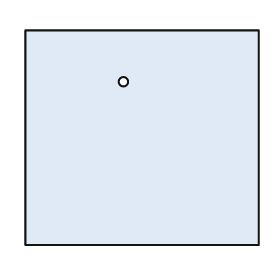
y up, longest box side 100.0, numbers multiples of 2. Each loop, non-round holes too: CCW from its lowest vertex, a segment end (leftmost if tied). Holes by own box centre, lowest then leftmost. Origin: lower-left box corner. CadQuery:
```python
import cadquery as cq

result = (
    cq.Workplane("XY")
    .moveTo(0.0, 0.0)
    .lineTo(100.0, 0.0)
    .lineTo(100.0, 92.0)
    .lineTo(0.0, 92.0)
    .close()
    .moveTo(42.0, 70.0)
    .circle(2.0)
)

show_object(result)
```